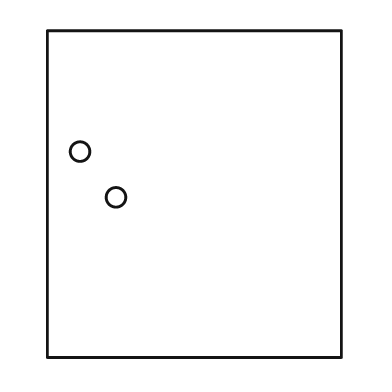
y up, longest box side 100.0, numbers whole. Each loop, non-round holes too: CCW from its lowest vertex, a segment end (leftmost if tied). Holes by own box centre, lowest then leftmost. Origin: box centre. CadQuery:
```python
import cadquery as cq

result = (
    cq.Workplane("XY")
    .moveTo(-45.0, -50.0)
    .lineTo(45.0, -50.0)
    .lineTo(45.0, 50.0)
    .lineTo(-45.0, 50.0)
    .close()
    .moveTo(-24.0, -1.0)
    .circle(3.0)
    .moveTo(-35.0, 13.0)
    .circle(3.0)
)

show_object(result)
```